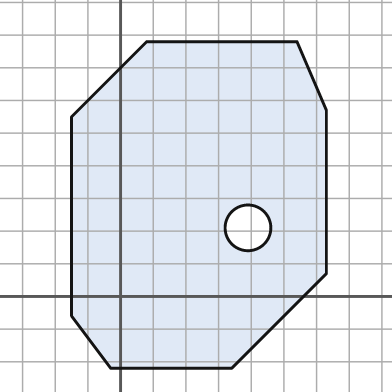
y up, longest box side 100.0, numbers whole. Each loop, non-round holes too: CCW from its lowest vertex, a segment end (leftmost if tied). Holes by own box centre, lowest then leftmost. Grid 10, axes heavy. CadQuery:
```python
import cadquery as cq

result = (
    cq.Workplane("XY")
    .moveTo(-3.0, -22.0)
    .lineTo(34.0, -22.0)
    .lineTo(63.0, 7.0)
    .lineTo(63.0, 57.0)
    .lineTo(54.0, 78.0)
    .lineTo(8.0, 78.0)
    .lineTo(-15.0, 55.0)
    .lineTo(-15.0, -6.0)
    .close()
    .moveTo(39.0, 21.0)
    .circle(7.0)
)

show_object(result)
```